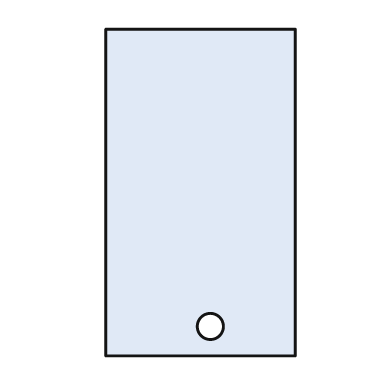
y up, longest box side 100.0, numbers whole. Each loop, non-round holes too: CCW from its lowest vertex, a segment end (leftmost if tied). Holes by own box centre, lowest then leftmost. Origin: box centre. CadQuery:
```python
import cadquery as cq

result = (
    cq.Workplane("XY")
    .moveTo(-29.0, -50.0)
    .lineTo(29.0, -50.0)
    .lineTo(29.0, 50.0)
    .lineTo(-29.0, 50.0)
    .close()
    .moveTo(3.0, -41.0)
    .circle(4.0)
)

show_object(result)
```